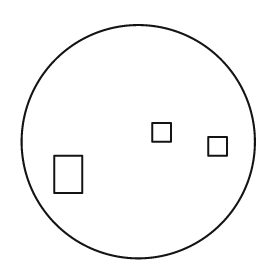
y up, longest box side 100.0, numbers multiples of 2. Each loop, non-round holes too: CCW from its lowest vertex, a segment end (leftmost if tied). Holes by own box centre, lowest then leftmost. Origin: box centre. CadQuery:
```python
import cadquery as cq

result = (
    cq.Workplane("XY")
    .moveTo(0.0, 0.0)
    .circle(50.0)
    .moveTo(-36.0, -22.0)
    .lineTo(-24.0, -22.0)
    .lineTo(-24.0, -6.0)
    .lineTo(-36.0, -6.0)
    .close()
    .moveTo(30.0, -6.0)
    .lineTo(38.0, -6.0)
    .lineTo(38.0, 2.0)
    .lineTo(30.0, 2.0)
    .close()
    .moveTo(6.0, 0.0)
    .lineTo(14.0, 0.0)
    .lineTo(14.0, 8.0)
    .lineTo(6.0, 8.0)
    .close()
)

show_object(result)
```